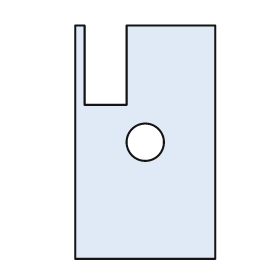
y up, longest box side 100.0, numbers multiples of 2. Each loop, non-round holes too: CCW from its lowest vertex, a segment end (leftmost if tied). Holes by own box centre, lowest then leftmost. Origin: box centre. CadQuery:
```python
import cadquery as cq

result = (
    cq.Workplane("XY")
    .moveTo(-30.0, -50.0)
    .lineTo(30.0, -50.0)
    .lineTo(30.0, 50.0)
    .lineTo(-8.0, 50.0)
    .lineTo(-8.0, 16.0)
    .lineTo(-26.0, 16.0)
    .lineTo(-26.0, 50.0)
    .lineTo(-30.0, 50.0)
    .close()
    .moveTo(0.0, 0.0)
    .circle(8.0)
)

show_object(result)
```